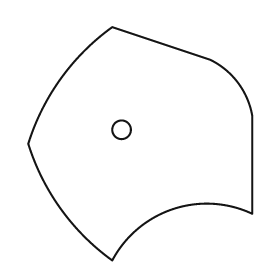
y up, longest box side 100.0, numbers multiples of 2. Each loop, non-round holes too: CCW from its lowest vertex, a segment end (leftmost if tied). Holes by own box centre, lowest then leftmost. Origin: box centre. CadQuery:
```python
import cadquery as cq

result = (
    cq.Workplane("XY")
    .moveTo(-12.0, -50.0)
    .threePointArc((14.0, -28.0), (48.0, -30.0))
    .lineTo(48.0, 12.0)
    .threePointArc((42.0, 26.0), (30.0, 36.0))
    .lineTo(-12.0, 50.0)
    .threePointArc((-34.0, 28.0), (-48.0, 0.0))
    .threePointArc((-34.0, -28.0), (-12.0, -50.0))
    .close()
    .moveTo(-8.0, 6.0)
    .circle(4.0)
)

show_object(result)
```